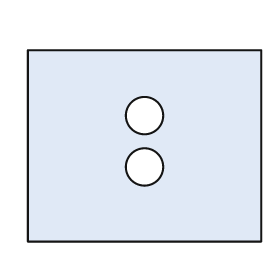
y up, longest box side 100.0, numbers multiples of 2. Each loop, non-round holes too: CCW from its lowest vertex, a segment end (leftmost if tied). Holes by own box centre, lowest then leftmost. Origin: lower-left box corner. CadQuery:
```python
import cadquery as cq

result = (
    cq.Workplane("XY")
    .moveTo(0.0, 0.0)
    .lineTo(100.0, 0.0)
    .lineTo(100.0, 82.0)
    .lineTo(0.0, 82.0)
    .close()
    .moveTo(50.0, 32.0)
    .circle(8.0)
    .moveTo(50.0, 54.0)
    .circle(8.0)
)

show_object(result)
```